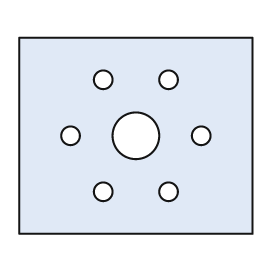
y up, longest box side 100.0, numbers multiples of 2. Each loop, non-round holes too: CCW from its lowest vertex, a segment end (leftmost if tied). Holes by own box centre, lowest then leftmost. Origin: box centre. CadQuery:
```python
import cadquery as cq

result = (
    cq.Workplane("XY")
    .moveTo(-50.0, -42.0)
    .lineTo(50.0, -42.0)
    .lineTo(50.0, 42.0)
    .lineTo(-50.0, 42.0)
    .close()
    .moveTo(-14.0, -24.0)
    .circle(4.0)
    .moveTo(14.0, -24.0)
    .circle(4.0)
    .moveTo(-28.0, 0.0)
    .circle(4.0)
    .moveTo(0.0, 0.0)
    .circle(10.0)
    .moveTo(28.0, 0.0)
    .circle(4.0)
    .moveTo(-14.0, 24.0)
    .circle(4.0)
    .moveTo(14.0, 24.0)
    .circle(4.0)
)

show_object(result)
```